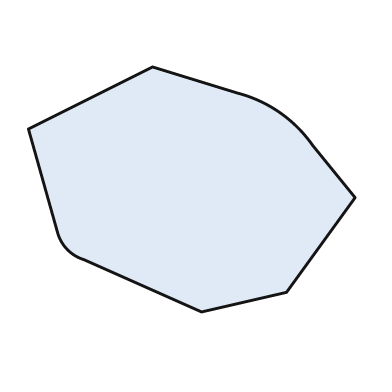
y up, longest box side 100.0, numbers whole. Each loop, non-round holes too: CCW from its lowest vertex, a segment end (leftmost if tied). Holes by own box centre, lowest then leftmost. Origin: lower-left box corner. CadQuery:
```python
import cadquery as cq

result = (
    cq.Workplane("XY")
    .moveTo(53.0, 0.0)
    .lineTo(79.0, 6.0)
    .lineTo(100.0, 35.0)
    .lineTo(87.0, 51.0)
    .threePointArc((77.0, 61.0), (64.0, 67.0))
    .lineTo(38.0, 75.0)
    .lineTo(0.0, 56.0)
    .lineTo(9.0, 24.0)
    .threePointArc((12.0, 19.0), (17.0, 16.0))
    .close()
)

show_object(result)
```